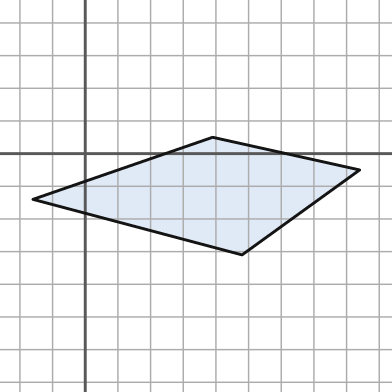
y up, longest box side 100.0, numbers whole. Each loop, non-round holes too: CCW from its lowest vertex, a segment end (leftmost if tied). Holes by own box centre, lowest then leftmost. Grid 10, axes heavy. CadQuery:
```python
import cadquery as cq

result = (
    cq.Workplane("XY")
    .moveTo(48.0, -31.0)
    .lineTo(84.0, -5.0)
    .lineTo(39.0, 5.0)
    .lineTo(-16.0, -14.0)
    .close()
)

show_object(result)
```